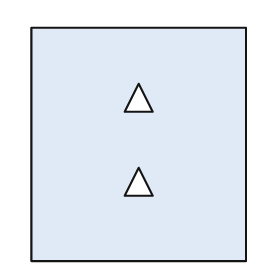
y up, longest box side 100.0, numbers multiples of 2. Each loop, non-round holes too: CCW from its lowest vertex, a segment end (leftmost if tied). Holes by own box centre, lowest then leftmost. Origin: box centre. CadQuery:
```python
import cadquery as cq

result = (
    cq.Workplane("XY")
    .moveTo(-46.0, -50.0)
    .lineTo(46.0, -50.0)
    .lineTo(46.0, 50.0)
    .lineTo(-46.0, 50.0)
    .close()
    .moveTo(-6.0, -22.0)
    .lineTo(6.0, -22.0)
    .lineTo(0.0, -10.0)
    .close()
    .moveTo(-6.0, 14.0)
    .lineTo(6.0, 14.0)
    .lineTo(0.0, 26.0)
    .close()
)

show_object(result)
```